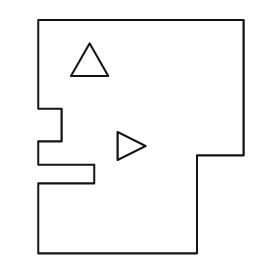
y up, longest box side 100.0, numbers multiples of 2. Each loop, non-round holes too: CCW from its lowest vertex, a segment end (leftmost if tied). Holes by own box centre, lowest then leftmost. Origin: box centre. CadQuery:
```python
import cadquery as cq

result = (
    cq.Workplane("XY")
    .moveTo(-44.0, -50.0)
    .lineTo(24.0, -50.0)
    .lineTo(24.0, -8.0)
    .lineTo(44.0, -8.0)
    .lineTo(44.0, 50.0)
    .lineTo(-44.0, 50.0)
    .lineTo(-44.0, 12.0)
    .lineTo(-34.0, 12.0)
    .lineTo(-34.0, -2.0)
    .lineTo(-44.0, -2.0)
    .lineTo(-44.0, -12.0)
    .lineTo(-20.0, -12.0)
    .lineTo(-20.0, -20.0)
    .lineTo(-44.0, -20.0)
    .close()
    .moveTo(-10.0, -10.0)
    .lineTo(2.0, -4.0)
    .lineTo(-10.0, 2.0)
    .close()
    .moveTo(-30.0, 26.0)
    .lineTo(-14.0, 26.0)
    .lineTo(-22.0, 40.0)
    .close()
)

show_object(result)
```